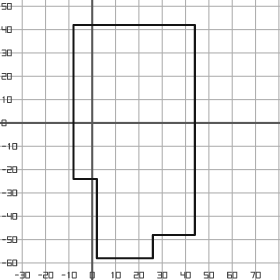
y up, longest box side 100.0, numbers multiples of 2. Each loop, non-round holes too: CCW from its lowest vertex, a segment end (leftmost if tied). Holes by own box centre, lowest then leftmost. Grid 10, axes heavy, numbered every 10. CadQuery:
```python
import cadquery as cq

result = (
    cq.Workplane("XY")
    .moveTo(2.0, -58.0)
    .lineTo(26.0, -58.0)
    .lineTo(26.0, -48.0)
    .lineTo(44.0, -48.0)
    .lineTo(44.0, 42.0)
    .lineTo(-8.0, 42.0)
    .lineTo(-8.0, -24.0)
    .lineTo(2.0, -24.0)
    .close()
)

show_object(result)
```